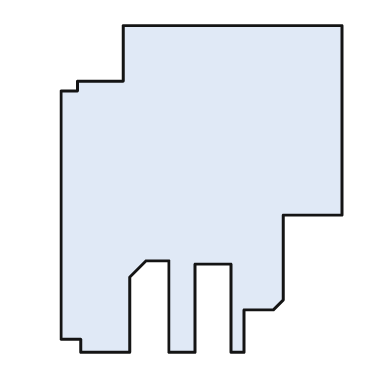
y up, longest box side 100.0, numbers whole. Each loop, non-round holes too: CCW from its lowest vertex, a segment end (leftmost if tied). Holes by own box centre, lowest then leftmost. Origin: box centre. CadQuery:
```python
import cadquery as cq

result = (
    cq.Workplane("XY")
    .moveTo(-37.0, -50.0)
    .lineTo(-22.0, -50.0)
    .lineTo(-22.0, -27.0)
    .lineTo(-17.0, -22.0)
    .lineTo(-10.0, -22.0)
    .lineTo(-10.0, -50.0)
    .lineTo(-2.0, -50.0)
    .lineTo(-2.0, -23.0)
    .lineTo(9.0, -23.0)
    .lineTo(9.0, -50.0)
    .lineTo(13.0, -50.0)
    .lineTo(13.0, -37.0)
    .lineTo(22.0, -37.0)
    .lineTo(25.0, -34.0)
    .lineTo(25.0, -8.0)
    .lineTo(43.0, -8.0)
    .lineTo(43.0, 50.0)
    .lineTo(-24.0, 50.0)
    .lineTo(-24.0, 33.0)
    .lineTo(-38.0, 33.0)
    .lineTo(-38.0, 30.0)
    .lineTo(-43.0, 30.0)
    .lineTo(-43.0, -46.0)
    .lineTo(-37.0, -46.0)
    .close()
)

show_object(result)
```